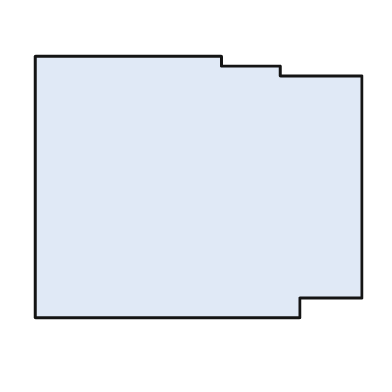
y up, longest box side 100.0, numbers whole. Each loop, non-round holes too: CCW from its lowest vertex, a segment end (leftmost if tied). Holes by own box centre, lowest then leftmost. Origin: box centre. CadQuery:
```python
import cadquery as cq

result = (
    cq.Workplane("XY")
    .moveTo(-50.0, -40.0)
    .lineTo(31.0, -40.0)
    .lineTo(31.0, -34.0)
    .lineTo(50.0, -34.0)
    .lineTo(50.0, 34.0)
    .lineTo(25.0, 34.0)
    .lineTo(25.0, 37.0)
    .lineTo(7.0, 37.0)
    .lineTo(7.0, 40.0)
    .lineTo(-50.0, 40.0)
    .close()
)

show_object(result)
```